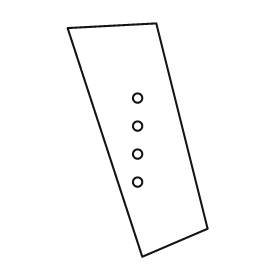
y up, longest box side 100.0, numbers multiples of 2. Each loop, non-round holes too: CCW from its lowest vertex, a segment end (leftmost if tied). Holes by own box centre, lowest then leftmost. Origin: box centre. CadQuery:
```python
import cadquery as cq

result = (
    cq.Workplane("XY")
    .moveTo(2.0, -50.0)
    .lineTo(30.0, -38.0)
    .lineTo(8.0, 50.0)
    .lineTo(-30.0, 48.0)
    .close()
    .moveTo(0.0, -18.0)
    .circle(2.0)
    .moveTo(0.0, -6.0)
    .circle(2.0)
    .moveTo(0.0, 6.0)
    .circle(2.0)
    .moveTo(0.0, 18.0)
    .circle(2.0)
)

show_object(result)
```